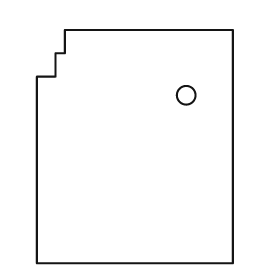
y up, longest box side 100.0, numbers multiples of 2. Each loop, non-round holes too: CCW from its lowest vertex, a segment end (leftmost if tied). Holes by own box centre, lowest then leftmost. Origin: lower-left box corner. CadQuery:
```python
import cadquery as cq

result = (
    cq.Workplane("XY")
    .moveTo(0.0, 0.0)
    .lineTo(84.0, 0.0)
    .lineTo(84.0, 100.0)
    .lineTo(12.0, 100.0)
    .lineTo(12.0, 90.0)
    .lineTo(8.0, 90.0)
    .lineTo(8.0, 80.0)
    .lineTo(0.0, 80.0)
    .close()
    .moveTo(64.0, 72.0)
    .circle(4.0)
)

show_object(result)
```